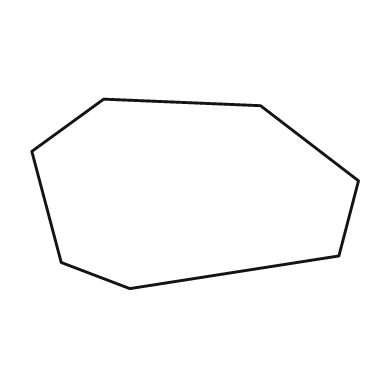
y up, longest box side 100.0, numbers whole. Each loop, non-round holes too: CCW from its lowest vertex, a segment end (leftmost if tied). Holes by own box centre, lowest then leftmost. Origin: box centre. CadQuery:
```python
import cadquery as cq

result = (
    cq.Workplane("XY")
    .moveTo(-20.0, -29.0)
    .lineTo(44.0, -19.0)
    .lineTo(50.0, 4.0)
    .lineTo(20.0, 27.0)
    .lineTo(-28.0, 29.0)
    .lineTo(-50.0, 13.0)
    .lineTo(-41.0, -21.0)
    .close()
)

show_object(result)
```